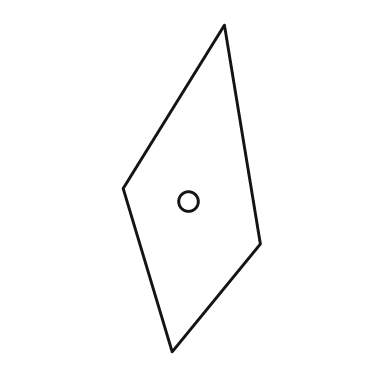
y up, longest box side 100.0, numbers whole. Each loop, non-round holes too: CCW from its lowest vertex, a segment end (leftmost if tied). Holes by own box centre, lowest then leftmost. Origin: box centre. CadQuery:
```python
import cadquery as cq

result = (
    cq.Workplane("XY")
    .moveTo(-6.0, -50.0)
    .lineTo(21.0, -17.0)
    .lineTo(10.0, 50.0)
    .lineTo(-21.0, 0.0)
    .close()
    .moveTo(-1.0, -4.0)
    .circle(3.0)
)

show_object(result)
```